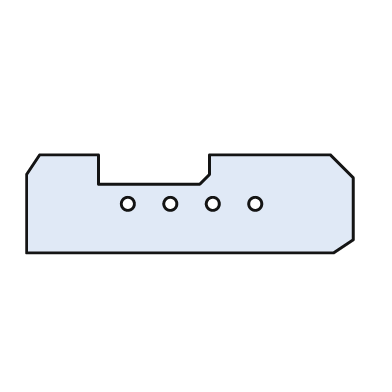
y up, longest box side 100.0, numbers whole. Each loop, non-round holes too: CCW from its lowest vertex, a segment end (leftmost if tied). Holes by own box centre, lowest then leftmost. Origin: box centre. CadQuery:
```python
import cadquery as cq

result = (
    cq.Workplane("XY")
    .moveTo(-50.0, -15.0)
    .lineTo(44.0, -15.0)
    .lineTo(50.0, -11.0)
    .lineTo(50.0, 8.0)
    .lineTo(43.0, 15.0)
    .lineTo(6.0, 15.0)
    .lineTo(6.0, 9.0)
    .lineTo(3.0, 6.0)
    .lineTo(-28.0, 6.0)
    .lineTo(-28.0, 15.0)
    .lineTo(-46.0, 15.0)
    .lineTo(-50.0, 9.0)
    .close()
    .moveTo(-19.0, 0.0)
    .circle(2.0)
    .moveTo(-6.0, 0.0)
    .circle(2.0)
    .moveTo(7.0, 0.0)
    .circle(2.0)
    .moveTo(20.0, 0.0)
    .circle(2.0)
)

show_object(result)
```